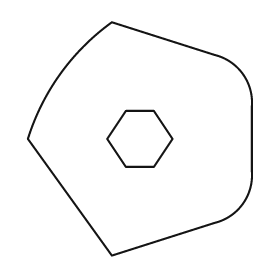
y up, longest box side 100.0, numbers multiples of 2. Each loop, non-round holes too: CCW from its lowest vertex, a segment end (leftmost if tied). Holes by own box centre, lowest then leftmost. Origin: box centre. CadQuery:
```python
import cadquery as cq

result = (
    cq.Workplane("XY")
    .moveTo(-12.0, -50.0)
    .lineTo(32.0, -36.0)
    .threePointArc((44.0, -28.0), (48.0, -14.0))
    .lineTo(48.0, 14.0)
    .threePointArc((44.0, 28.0), (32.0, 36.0))
    .lineTo(-12.0, 50.0)
    .threePointArc((-34.0, 28.0), (-48.0, 0.0))
    .close()
    .moveTo(-6.0, -12.0)
    .lineTo(6.0, -12.0)
    .lineTo(14.0, 0.0)
    .lineTo(6.0, 12.0)
    .lineTo(-6.0, 12.0)
    .lineTo(-14.0, 0.0)
    .close()
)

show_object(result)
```